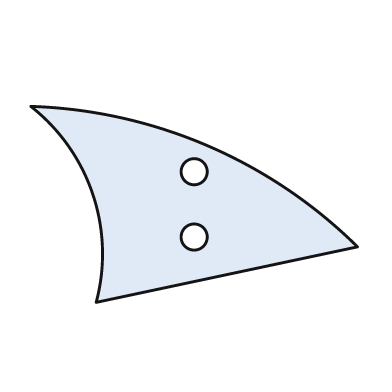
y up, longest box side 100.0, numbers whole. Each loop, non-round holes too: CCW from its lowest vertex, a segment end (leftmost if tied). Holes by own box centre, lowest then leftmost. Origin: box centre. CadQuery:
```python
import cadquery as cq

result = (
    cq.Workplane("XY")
    .moveTo(-30.0, -30.0)
    .lineTo(50.0, -13.0)
    .threePointArc((4.0, 18.0), (-50.0, 30.0))
    .threePointArc((-31.0, 3.0), (-30.0, -30.0))
    .close()
    .moveTo(0.0, -10.0)
    .circle(4.0)
    .moveTo(0.0, 10.0)
    .circle(4.0)
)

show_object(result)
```